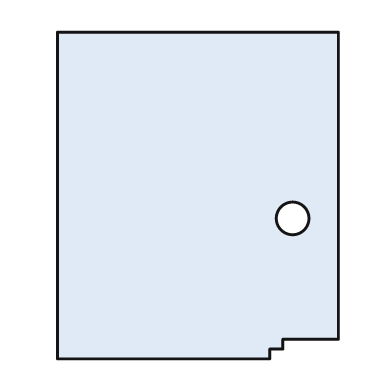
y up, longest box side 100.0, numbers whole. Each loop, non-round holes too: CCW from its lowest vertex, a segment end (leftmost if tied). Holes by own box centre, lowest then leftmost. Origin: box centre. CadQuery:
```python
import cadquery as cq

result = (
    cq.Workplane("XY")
    .moveTo(-43.0, -50.0)
    .lineTo(22.0, -50.0)
    .lineTo(22.0, -47.0)
    .lineTo(26.0, -47.0)
    .lineTo(26.0, -44.0)
    .lineTo(43.0, -44.0)
    .lineTo(43.0, 50.0)
    .lineTo(-43.0, 50.0)
    .close()
    .moveTo(29.0, -7.0)
    .circle(5.0)
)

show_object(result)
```